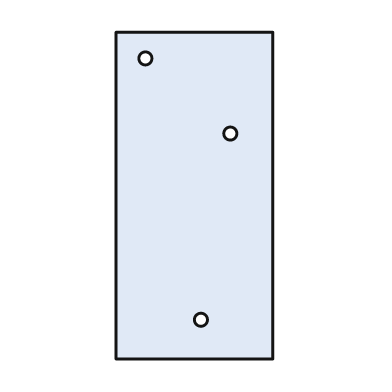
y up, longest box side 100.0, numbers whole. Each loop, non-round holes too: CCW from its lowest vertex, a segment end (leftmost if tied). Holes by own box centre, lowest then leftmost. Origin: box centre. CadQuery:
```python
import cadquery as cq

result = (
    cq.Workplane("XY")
    .moveTo(-24.0, -50.0)
    .lineTo(24.0, -50.0)
    .lineTo(24.0, 50.0)
    .lineTo(-24.0, 50.0)
    .close()
    .moveTo(2.0, -38.0)
    .circle(2.0)
    .moveTo(11.0, 19.0)
    .circle(2.0)
    .moveTo(-15.0, 42.0)
    .circle(2.0)
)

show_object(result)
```